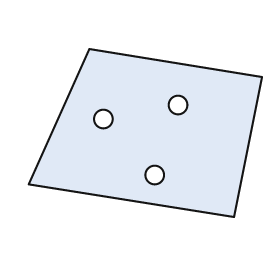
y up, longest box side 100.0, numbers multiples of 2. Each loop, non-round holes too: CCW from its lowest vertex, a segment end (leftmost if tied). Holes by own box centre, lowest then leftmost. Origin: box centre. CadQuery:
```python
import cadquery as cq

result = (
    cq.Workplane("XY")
    .moveTo(38.0, -36.0)
    .lineTo(50.0, 24.0)
    .lineTo(-24.0, 36.0)
    .lineTo(-50.0, -22.0)
    .close()
    .moveTo(4.0, -18.0)
    .circle(4.0)
    .moveTo(-18.0, 6.0)
    .circle(4.0)
    .moveTo(14.0, 12.0)
    .circle(4.0)
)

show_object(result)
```